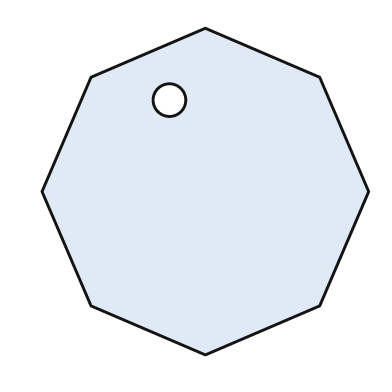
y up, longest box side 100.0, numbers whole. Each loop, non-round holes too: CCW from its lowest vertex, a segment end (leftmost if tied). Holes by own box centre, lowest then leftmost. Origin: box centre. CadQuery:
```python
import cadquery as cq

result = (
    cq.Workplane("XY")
    .moveTo(0.0, -50.0)
    .lineTo(35.0, -35.0)
    .lineTo(50.0, 0.0)
    .lineTo(35.0, 35.0)
    .lineTo(0.0, 50.0)
    .lineTo(-35.0, 35.0)
    .lineTo(-50.0, 0.0)
    .lineTo(-35.0, -35.0)
    .close()
    .moveTo(-11.0, 28.0)
    .circle(5.0)
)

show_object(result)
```